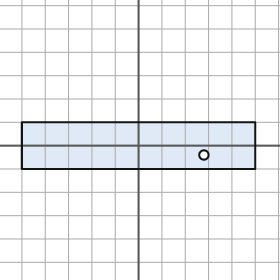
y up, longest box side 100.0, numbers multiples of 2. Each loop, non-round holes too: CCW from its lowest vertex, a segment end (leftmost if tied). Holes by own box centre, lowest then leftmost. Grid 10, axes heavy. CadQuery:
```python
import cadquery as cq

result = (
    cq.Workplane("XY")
    .moveTo(-50.0, -10.0)
    .lineTo(50.0, -10.0)
    .lineTo(50.0, 10.0)
    .lineTo(-50.0, 10.0)
    .close()
    .moveTo(28.0, -4.0)
    .circle(2.0)
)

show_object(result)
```